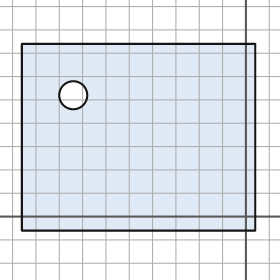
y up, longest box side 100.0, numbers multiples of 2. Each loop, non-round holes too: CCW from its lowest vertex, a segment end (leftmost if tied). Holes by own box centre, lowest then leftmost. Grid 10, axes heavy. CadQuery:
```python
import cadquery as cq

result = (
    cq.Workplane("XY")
    .moveTo(-96.0, -6.0)
    .lineTo(4.0, -6.0)
    .lineTo(4.0, 74.0)
    .lineTo(-96.0, 74.0)
    .close()
    .moveTo(-74.0, 52.0)
    .circle(6.0)
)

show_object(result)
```